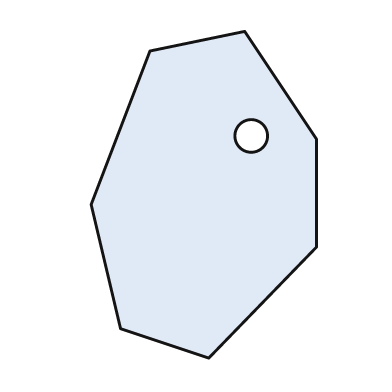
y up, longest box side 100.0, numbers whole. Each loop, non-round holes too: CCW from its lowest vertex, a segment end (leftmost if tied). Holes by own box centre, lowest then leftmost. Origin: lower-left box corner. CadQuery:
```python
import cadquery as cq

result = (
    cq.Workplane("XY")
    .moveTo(36.0, 0.0)
    .lineTo(69.0, 34.0)
    .lineTo(69.0, 67.0)
    .lineTo(47.0, 100.0)
    .lineTo(18.0, 94.0)
    .lineTo(0.0, 47.0)
    .lineTo(9.0, 9.0)
    .close()
    .moveTo(49.0, 68.0)
    .circle(5.0)
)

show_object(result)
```